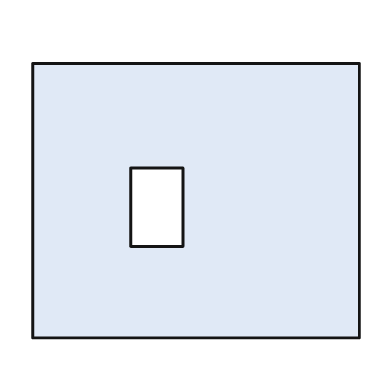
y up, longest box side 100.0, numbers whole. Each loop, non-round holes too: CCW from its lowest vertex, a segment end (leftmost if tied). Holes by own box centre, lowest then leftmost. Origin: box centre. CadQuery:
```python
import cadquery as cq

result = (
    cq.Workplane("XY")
    .moveTo(-50.0, -42.0)
    .lineTo(50.0, -42.0)
    .lineTo(50.0, 42.0)
    .lineTo(-50.0, 42.0)
    .close()
    .moveTo(-20.0, -14.0)
    .lineTo(-4.0, -14.0)
    .lineTo(-4.0, 10.0)
    .lineTo(-20.0, 10.0)
    .close()
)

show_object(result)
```